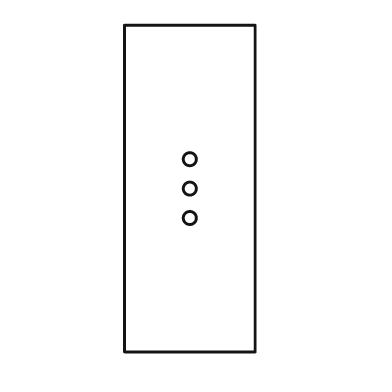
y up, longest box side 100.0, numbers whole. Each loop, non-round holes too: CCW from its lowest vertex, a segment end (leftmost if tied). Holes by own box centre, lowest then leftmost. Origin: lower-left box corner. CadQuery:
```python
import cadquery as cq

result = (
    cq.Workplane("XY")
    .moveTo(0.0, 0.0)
    .lineTo(40.0, 0.0)
    .lineTo(40.0, 100.0)
    .lineTo(0.0, 100.0)
    .close()
    .moveTo(20.0, 41.0)
    .circle(2.0)
    .moveTo(20.0, 50.0)
    .circle(2.0)
    .moveTo(20.0, 59.0)
    .circle(2.0)
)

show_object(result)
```